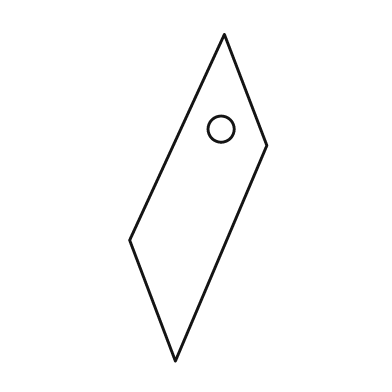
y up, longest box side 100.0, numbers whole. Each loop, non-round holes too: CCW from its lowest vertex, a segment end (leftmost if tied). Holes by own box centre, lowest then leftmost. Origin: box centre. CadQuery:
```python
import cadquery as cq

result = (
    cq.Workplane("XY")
    .moveTo(-7.0, -50.0)
    .lineTo(21.0, 16.0)
    .lineTo(8.0, 50.0)
    .lineTo(-21.0, -13.0)
    .close()
    .moveTo(7.0, 21.0)
    .circle(4.0)
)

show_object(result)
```